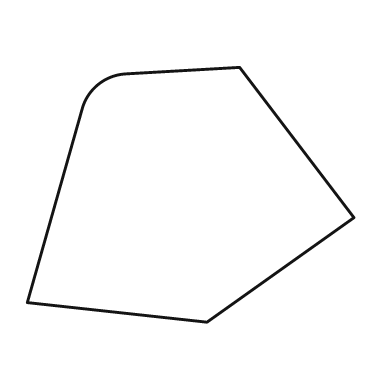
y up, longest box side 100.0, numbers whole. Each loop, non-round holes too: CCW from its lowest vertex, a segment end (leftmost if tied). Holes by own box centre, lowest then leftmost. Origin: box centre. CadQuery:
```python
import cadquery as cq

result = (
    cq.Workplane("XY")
    .moveTo(5.0, -39.0)
    .lineTo(50.0, -7.0)
    .lineTo(15.0, 39.0)
    .lineTo(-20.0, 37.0)
    .threePointArc((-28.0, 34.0), (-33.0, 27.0))
    .lineTo(-50.0, -33.0)
    .close()
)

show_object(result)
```